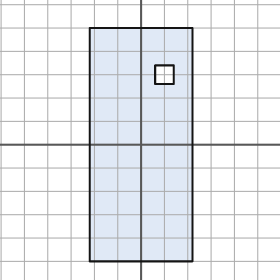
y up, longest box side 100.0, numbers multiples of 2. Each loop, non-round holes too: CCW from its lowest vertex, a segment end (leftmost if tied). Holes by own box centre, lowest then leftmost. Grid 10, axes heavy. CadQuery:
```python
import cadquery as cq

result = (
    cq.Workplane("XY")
    .moveTo(-22.0, -50.0)
    .lineTo(22.0, -50.0)
    .lineTo(22.0, 50.0)
    .lineTo(-22.0, 50.0)
    .close()
    .moveTo(6.0, 26.0)
    .lineTo(14.0, 26.0)
    .lineTo(14.0, 34.0)
    .lineTo(6.0, 34.0)
    .close()
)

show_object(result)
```